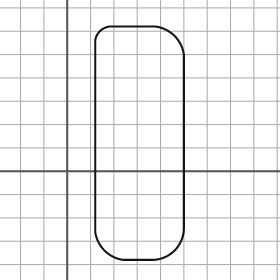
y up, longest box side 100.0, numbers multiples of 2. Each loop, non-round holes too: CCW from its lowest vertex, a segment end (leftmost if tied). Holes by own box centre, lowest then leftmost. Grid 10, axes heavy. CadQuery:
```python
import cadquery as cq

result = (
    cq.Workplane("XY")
    .moveTo(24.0, -38.0)
    .lineTo(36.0, -38.0)
    .threePointArc((46.0, -34.0), (50.0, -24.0))
    .lineTo(50.0, 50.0)
    .threePointArc((46.0, 58.0), (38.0, 62.0))
    .lineTo(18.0, 62.0)
    .threePointArc((14.0, 60.0), (12.0, 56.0))
    .lineTo(12.0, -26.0)
    .threePointArc((16.0, -34.0), (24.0, -38.0))
    .close()
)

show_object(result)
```